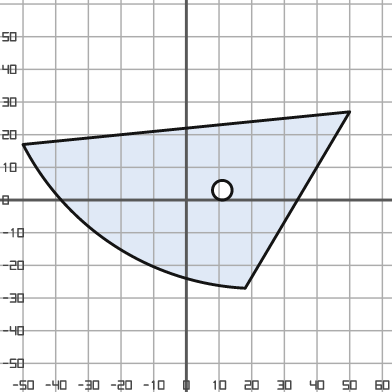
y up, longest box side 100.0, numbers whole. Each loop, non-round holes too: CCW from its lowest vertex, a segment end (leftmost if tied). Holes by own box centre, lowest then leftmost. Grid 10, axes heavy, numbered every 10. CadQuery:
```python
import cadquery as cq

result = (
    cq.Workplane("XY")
    .moveTo(18.0, -27.0)
    .lineTo(50.0, 27.0)
    .lineTo(-50.0, 17.0)
    .threePointArc((-22.0, -14.0), (18.0, -27.0))
    .close()
    .moveTo(11.0, 3.0)
    .circle(3.0)
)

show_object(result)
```